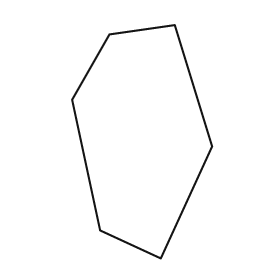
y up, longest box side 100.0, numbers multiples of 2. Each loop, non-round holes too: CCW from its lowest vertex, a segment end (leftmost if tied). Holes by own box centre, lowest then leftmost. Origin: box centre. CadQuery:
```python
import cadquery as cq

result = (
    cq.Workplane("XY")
    .moveTo(8.0, -50.0)
    .lineTo(30.0, -2.0)
    .lineTo(14.0, 50.0)
    .lineTo(-14.0, 46.0)
    .lineTo(-30.0, 18.0)
    .lineTo(-18.0, -38.0)
    .close()
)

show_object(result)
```